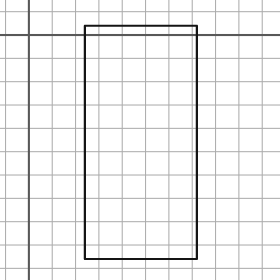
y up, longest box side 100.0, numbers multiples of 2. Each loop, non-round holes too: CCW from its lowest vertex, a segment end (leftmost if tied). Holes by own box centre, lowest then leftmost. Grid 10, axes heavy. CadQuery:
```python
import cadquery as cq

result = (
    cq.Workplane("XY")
    .moveTo(24.0, -96.0)
    .lineTo(72.0, -96.0)
    .lineTo(72.0, 4.0)
    .lineTo(24.0, 4.0)
    .close()
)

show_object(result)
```